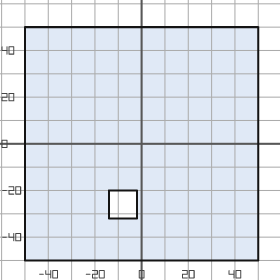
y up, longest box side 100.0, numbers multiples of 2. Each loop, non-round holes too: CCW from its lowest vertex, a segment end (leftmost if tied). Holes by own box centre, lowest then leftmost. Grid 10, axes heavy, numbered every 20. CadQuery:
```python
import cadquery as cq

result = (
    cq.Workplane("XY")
    .moveTo(-50.0, -50.0)
    .lineTo(50.0, -50.0)
    .lineTo(50.0, 50.0)
    .lineTo(-50.0, 50.0)
    .close()
    .moveTo(-14.0, -32.0)
    .lineTo(-2.0, -32.0)
    .lineTo(-2.0, -20.0)
    .lineTo(-14.0, -20.0)
    .close()
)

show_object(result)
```